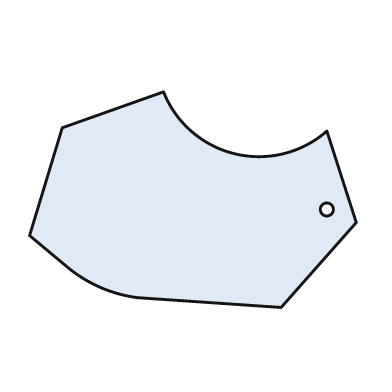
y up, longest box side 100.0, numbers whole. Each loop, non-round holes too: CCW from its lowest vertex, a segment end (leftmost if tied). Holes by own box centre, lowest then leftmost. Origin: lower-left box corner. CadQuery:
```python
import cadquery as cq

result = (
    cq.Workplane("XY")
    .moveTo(77.0, 0.0)
    .lineTo(100.0, 26.0)
    .lineTo(91.0, 54.0)
    .threePointArc((63.0, 47.0), (41.0, 66.0))
    .lineTo(10.0, 55.0)
    .lineTo(0.0, 22.0)
    .lineTo(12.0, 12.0)
    .threePointArc((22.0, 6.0), (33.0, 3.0))
    .close()
    .moveTo(91.0, 30.0)
    .circle(2.0)
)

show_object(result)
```